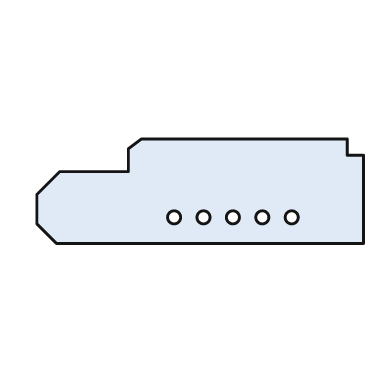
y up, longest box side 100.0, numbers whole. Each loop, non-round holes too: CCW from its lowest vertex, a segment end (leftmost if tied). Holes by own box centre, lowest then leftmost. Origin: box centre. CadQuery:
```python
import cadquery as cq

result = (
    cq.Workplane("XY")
    .moveTo(-44.0, -16.0)
    .lineTo(50.0, -16.0)
    .lineTo(50.0, 11.0)
    .lineTo(45.0, 11.0)
    .lineTo(45.0, 16.0)
    .lineTo(-18.0, 16.0)
    .lineTo(-22.0, 13.0)
    .lineTo(-22.0, 6.0)
    .lineTo(-43.0, 6.0)
    .lineTo(-50.0, -1.0)
    .lineTo(-50.0, -10.0)
    .close()
    .moveTo(-8.0, -8.0)
    .circle(2.0)
    .moveTo(1.0, -8.0)
    .circle(2.0)
    .moveTo(10.0, -8.0)
    .circle(2.0)
    .moveTo(19.0, -8.0)
    .circle(2.0)
    .moveTo(28.0, -8.0)
    .circle(2.0)
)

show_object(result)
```